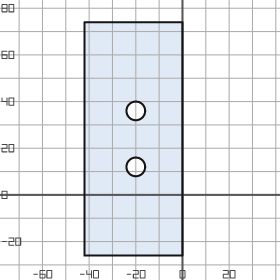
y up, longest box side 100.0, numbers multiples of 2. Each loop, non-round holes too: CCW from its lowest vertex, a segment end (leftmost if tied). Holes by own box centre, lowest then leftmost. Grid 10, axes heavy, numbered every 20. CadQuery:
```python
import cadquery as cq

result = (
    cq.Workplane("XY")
    .moveTo(-42.0, -26.0)
    .lineTo(0.0, -26.0)
    .lineTo(0.0, 74.0)
    .lineTo(-42.0, 74.0)
    .close()
    .moveTo(-20.0, 12.0)
    .circle(4.0)
    .moveTo(-20.0, 36.0)
    .circle(4.0)
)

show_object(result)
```